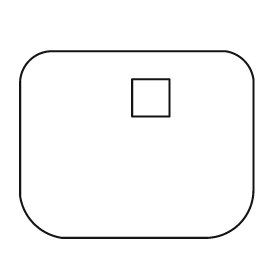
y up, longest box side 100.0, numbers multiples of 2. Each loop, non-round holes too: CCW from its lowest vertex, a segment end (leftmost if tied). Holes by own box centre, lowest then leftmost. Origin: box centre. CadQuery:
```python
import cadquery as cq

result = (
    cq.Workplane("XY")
    .moveTo(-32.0, -40.0)
    .lineTo(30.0, -40.0)
    .threePointArc((44.0, -34.0), (50.0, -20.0))
    .lineTo(50.0, 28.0)
    .threePointArc((46.0, 36.0), (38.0, 40.0))
    .lineTo(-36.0, 40.0)
    .threePointArc((-46.0, 36.0), (-50.0, 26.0))
    .lineTo(-50.0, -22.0)
    .threePointArc((-44.0, -34.0), (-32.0, -40.0))
    .close()
    .moveTo(-2.0, 12.0)
    .lineTo(14.0, 12.0)
    .lineTo(14.0, 28.0)
    .lineTo(-2.0, 28.0)
    .close()
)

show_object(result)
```